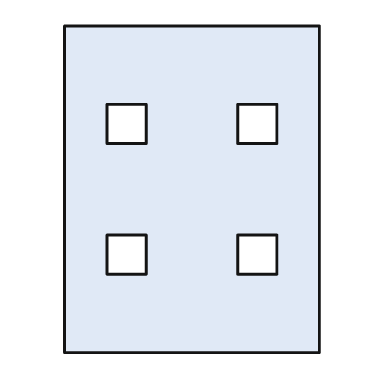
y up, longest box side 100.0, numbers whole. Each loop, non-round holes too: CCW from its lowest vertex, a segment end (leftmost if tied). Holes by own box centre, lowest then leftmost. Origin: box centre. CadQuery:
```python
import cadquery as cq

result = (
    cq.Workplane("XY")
    .moveTo(-39.0, -50.0)
    .lineTo(39.0, -50.0)
    .lineTo(39.0, 50.0)
    .lineTo(-39.0, 50.0)
    .close()
    .moveTo(-26.0, -26.0)
    .lineTo(-14.0, -26.0)
    .lineTo(-14.0, -14.0)
    .lineTo(-26.0, -14.0)
    .close()
    .moveTo(14.0, -26.0)
    .lineTo(26.0, -26.0)
    .lineTo(26.0, -14.0)
    .lineTo(14.0, -14.0)
    .close()
    .moveTo(-26.0, 14.0)
    .lineTo(-14.0, 14.0)
    .lineTo(-14.0, 26.0)
    .lineTo(-26.0, 26.0)
    .close()
    .moveTo(14.0, 14.0)
    .lineTo(26.0, 14.0)
    .lineTo(26.0, 26.0)
    .lineTo(14.0, 26.0)
    .close()
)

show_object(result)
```